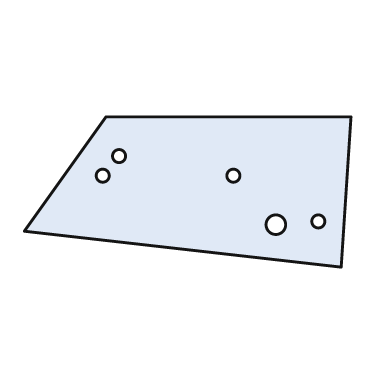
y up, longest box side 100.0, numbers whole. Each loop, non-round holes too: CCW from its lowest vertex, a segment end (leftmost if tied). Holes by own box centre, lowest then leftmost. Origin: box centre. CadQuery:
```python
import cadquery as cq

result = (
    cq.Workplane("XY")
    .moveTo(47.0, -23.0)
    .lineTo(50.0, 23.0)
    .lineTo(-25.0, 23.0)
    .lineTo(-50.0, -12.0)
    .close()
    .moveTo(27.0, -10.0)
    .circle(3.0)
    .moveTo(40.0, -9.0)
    .circle(2.0)
    .moveTo(-26.0, 5.0)
    .circle(2.0)
    .moveTo(14.0, 5.0)
    .circle(2.0)
    .moveTo(-21.0, 11.0)
    .circle(2.0)
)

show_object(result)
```